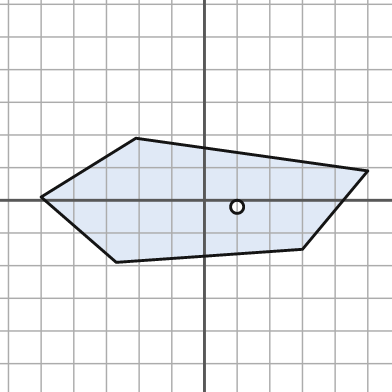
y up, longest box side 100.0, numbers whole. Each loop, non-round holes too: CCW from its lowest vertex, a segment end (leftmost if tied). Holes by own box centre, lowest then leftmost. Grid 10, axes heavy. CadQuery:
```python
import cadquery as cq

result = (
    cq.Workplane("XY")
    .moveTo(-27.0, -19.0)
    .lineTo(30.0, -15.0)
    .lineTo(50.0, 9.0)
    .lineTo(-21.0, 19.0)
    .lineTo(-50.0, 1.0)
    .close()
    .moveTo(10.0, -2.0)
    .circle(2.0)
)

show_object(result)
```